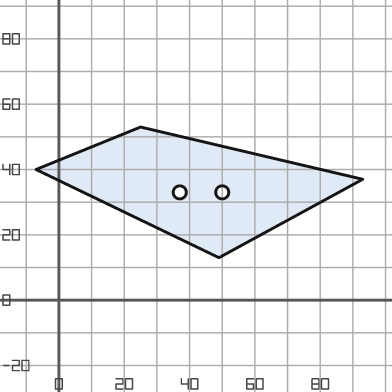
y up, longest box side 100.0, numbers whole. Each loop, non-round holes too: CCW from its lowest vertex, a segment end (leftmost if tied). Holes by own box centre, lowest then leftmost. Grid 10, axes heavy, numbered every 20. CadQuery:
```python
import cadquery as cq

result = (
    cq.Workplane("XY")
    .moveTo(49.0, 13.0)
    .lineTo(93.0, 37.0)
    .lineTo(25.0, 53.0)
    .lineTo(-7.0, 40.0)
    .close()
    .moveTo(37.0, 33.0)
    .circle(2.0)
    .moveTo(50.0, 33.0)
    .circle(2.0)
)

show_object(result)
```